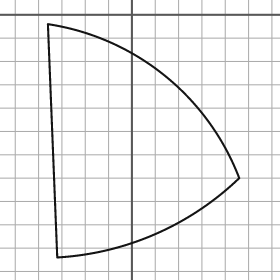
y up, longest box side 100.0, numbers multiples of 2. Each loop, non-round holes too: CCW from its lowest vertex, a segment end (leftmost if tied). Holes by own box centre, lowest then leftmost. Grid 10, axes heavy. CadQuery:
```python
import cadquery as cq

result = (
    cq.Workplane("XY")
    .moveTo(-32.0, -104.0)
    .threePointArc((10.0, -94.0), (46.0, -70.0))
    .threePointArc((14.0, -26.0), (-36.0, -4.0))
    .close()
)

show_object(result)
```